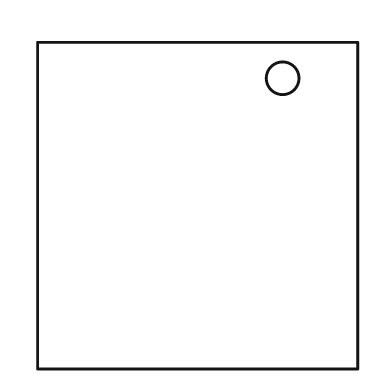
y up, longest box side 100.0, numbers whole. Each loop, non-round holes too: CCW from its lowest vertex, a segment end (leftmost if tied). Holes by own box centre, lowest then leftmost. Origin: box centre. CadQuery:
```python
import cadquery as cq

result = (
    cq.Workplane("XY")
    .moveTo(-49.0, -50.0)
    .lineTo(49.0, -50.0)
    .lineTo(49.0, 50.0)
    .lineTo(-49.0, 50.0)
    .close()
    .moveTo(26.0, 39.0)
    .circle(5.0)
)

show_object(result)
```